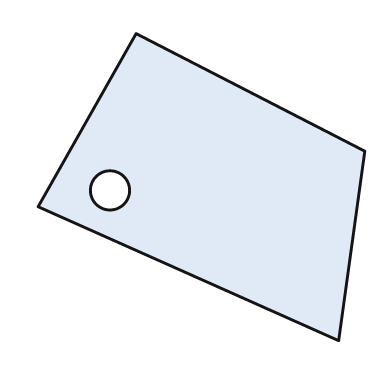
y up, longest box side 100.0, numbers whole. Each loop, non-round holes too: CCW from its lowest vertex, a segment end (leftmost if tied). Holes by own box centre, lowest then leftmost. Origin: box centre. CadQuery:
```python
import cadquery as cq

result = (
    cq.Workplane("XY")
    .moveTo(42.0, -47.0)
    .lineTo(50.0, 11.0)
    .lineTo(-20.0, 47.0)
    .lineTo(-50.0, -6.0)
    .close()
    .moveTo(-28.0, -1.0)
    .circle(6.0)
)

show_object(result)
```